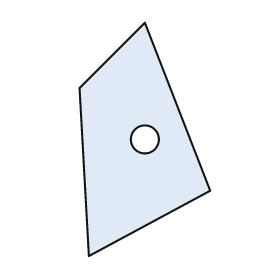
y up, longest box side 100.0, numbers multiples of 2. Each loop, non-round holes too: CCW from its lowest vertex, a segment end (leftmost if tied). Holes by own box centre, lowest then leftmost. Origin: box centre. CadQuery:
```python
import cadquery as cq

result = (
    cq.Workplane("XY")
    .moveTo(-24.0, -50.0)
    .lineTo(28.0, -22.0)
    .lineTo(0.0, 50.0)
    .lineTo(-28.0, 22.0)
    .close()
    .moveTo(0.0, 0.0)
    .circle(6.0)
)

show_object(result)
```